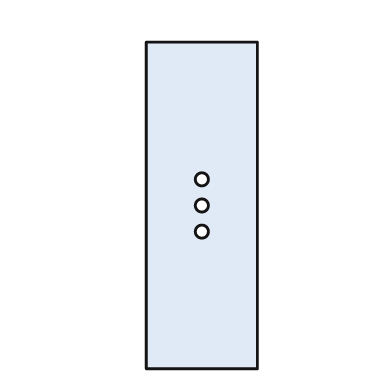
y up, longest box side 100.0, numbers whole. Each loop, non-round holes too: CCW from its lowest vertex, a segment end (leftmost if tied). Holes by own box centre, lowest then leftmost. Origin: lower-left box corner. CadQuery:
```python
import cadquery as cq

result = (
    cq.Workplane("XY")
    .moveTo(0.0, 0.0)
    .lineTo(34.0, 0.0)
    .lineTo(34.0, 100.0)
    .lineTo(0.0, 100.0)
    .close()
    .moveTo(17.0, 42.0)
    .circle(2.0)
    .moveTo(17.0, 50.0)
    .circle(2.0)
    .moveTo(17.0, 58.0)
    .circle(2.0)
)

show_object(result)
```